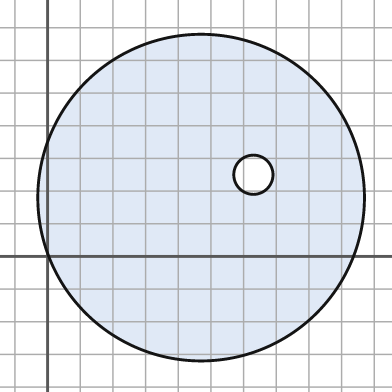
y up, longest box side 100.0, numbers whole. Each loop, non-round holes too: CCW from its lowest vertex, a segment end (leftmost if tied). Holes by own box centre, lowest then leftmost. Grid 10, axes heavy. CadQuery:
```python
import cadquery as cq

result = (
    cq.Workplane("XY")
    .moveTo(47.0, 18.0)
    .circle(50.0)
    .moveTo(63.0, 25.0)
    .circle(6.0)
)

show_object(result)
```